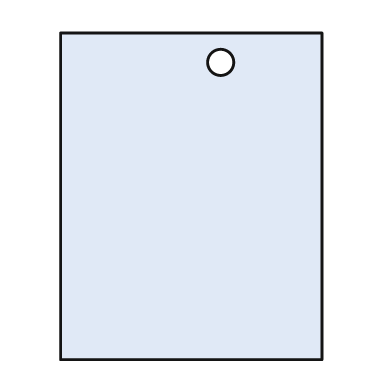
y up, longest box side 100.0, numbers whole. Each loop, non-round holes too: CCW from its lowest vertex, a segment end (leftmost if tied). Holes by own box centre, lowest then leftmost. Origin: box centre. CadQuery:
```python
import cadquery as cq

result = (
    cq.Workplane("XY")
    .moveTo(-40.0, -50.0)
    .lineTo(40.0, -50.0)
    .lineTo(40.0, 50.0)
    .lineTo(-40.0, 50.0)
    .close()
    .moveTo(9.0, 41.0)
    .circle(4.0)
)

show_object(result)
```